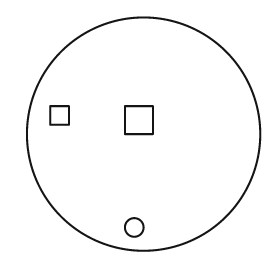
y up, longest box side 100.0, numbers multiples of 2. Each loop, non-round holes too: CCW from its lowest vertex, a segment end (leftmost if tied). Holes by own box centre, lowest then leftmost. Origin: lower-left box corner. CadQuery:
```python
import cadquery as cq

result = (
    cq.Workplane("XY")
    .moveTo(50.0, 50.0)
    .circle(50.0)
    .moveTo(46.0, 10.0)
    .circle(4.0)
    .moveTo(42.0, 50.0)
    .lineTo(54.0, 50.0)
    .lineTo(54.0, 62.0)
    .lineTo(42.0, 62.0)
    .close()
    .moveTo(10.0, 54.0)
    .lineTo(18.0, 54.0)
    .lineTo(18.0, 62.0)
    .lineTo(10.0, 62.0)
    .close()
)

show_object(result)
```